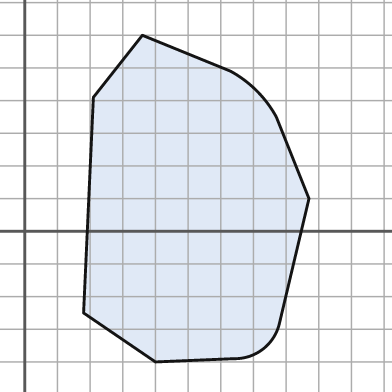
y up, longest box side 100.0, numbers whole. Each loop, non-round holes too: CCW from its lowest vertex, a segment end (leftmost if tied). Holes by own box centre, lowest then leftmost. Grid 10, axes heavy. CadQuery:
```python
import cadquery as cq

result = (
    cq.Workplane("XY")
    .moveTo(40.0, -40.0)
    .lineTo(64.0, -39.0)
    .threePointArc((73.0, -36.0), (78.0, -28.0))
    .lineTo(87.0, 10.0)
    .lineTo(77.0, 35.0)
    .threePointArc((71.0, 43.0), (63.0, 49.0))
    .lineTo(36.0, 60.0)
    .lineTo(21.0, 41.0)
    .lineTo(18.0, -25.0)
    .close()
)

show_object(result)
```